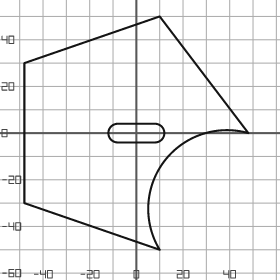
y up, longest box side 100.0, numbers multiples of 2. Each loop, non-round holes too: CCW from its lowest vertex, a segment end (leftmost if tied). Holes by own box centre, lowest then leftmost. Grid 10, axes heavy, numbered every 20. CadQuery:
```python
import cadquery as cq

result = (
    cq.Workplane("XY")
    .moveTo(10.0, -50.0)
    .threePointArc((12.0, -12.0), (48.0, 0.0))
    .lineTo(10.0, 50.0)
    .lineTo(-48.0, 30.0)
    .lineTo(-48.0, -30.0)
    .close()
    .moveTo(-8.0, -4.0)
    .lineTo(8.0, -4.0)
    .threePointArc((12.0, 0.0), (8.0, 4.0))
    .lineTo(-8.0, 4.0)
    .threePointArc((-12.0, 0.0), (-8.0, -4.0))
    .close()
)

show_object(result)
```